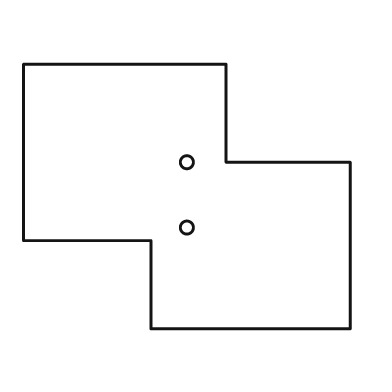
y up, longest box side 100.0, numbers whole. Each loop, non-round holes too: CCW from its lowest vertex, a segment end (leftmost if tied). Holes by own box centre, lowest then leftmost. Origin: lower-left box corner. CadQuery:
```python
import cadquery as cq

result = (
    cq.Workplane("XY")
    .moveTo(39.0, 0.0)
    .lineTo(100.0, 0.0)
    .lineTo(100.0, 51.0)
    .lineTo(62.0, 51.0)
    .lineTo(62.0, 81.0)
    .lineTo(0.0, 81.0)
    .lineTo(0.0, 27.0)
    .lineTo(39.0, 27.0)
    .close()
    .moveTo(50.0, 31.0)
    .circle(2.0)
    .moveTo(50.0, 51.0)
    .circle(2.0)
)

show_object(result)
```